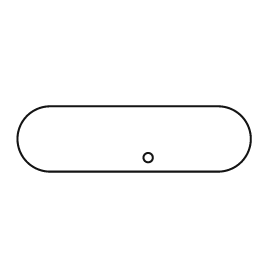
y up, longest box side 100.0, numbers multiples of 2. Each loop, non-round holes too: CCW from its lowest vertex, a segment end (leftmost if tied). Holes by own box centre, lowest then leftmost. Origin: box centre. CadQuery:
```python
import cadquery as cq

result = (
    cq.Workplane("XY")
    .moveTo(-36.0, -14.0)
    .lineTo(36.0, -14.0)
    .threePointArc((50.0, 0.0), (36.0, 14.0))
    .lineTo(-36.0, 14.0)
    .threePointArc((-50.0, 0.0), (-36.0, -14.0))
    .close()
    .moveTo(6.0, -8.0)
    .circle(2.0)
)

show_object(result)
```